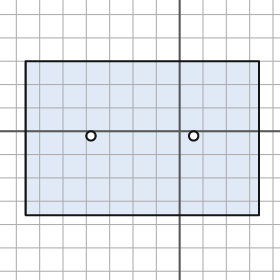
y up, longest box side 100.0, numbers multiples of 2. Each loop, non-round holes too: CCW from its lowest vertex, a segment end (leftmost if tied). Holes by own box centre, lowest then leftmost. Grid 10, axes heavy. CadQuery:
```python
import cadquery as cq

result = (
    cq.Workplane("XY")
    .moveTo(-66.0, -36.0)
    .lineTo(34.0, -36.0)
    .lineTo(34.0, 30.0)
    .lineTo(-66.0, 30.0)
    .close()
    .moveTo(-38.0, -2.0)
    .circle(2.0)
    .moveTo(6.0, -2.0)
    .circle(2.0)
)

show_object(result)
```